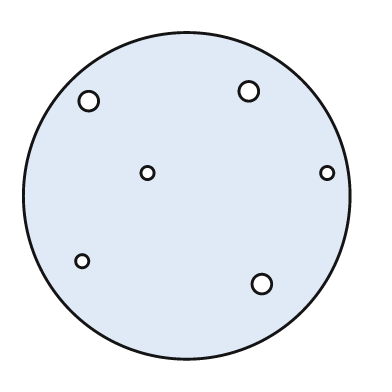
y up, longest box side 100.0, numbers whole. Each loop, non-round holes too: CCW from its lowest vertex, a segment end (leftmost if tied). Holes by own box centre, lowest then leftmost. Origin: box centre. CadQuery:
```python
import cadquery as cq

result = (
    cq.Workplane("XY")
    .moveTo(0.0, 0.0)
    .circle(50.0)
    .moveTo(23.0, -27.0)
    .circle(3.0)
    .moveTo(-32.0, -20.0)
    .circle(2.0)
    .moveTo(-12.0, 7.0)
    .circle(2.0)
    .moveTo(43.0, 7.0)
    .circle(2.0)
    .moveTo(-30.0, 29.0)
    .circle(3.0)
    .moveTo(19.0, 32.0)
    .circle(3.0)
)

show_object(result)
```